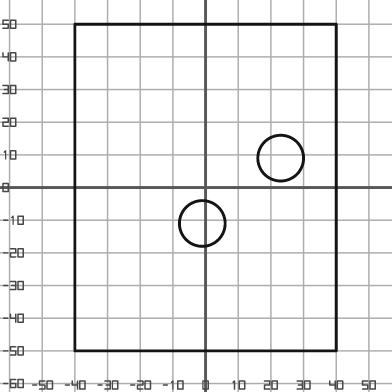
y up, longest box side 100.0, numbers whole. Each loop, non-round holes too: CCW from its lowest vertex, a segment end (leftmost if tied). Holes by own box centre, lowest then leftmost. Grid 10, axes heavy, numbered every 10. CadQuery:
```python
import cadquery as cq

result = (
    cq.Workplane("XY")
    .moveTo(-40.0, -50.0)
    .lineTo(40.0, -50.0)
    .lineTo(40.0, 50.0)
    .lineTo(-40.0, 50.0)
    .close()
    .moveTo(-1.0, -11.0)
    .circle(7.0)
    .moveTo(23.0, 9.0)
    .circle(7.0)
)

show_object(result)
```